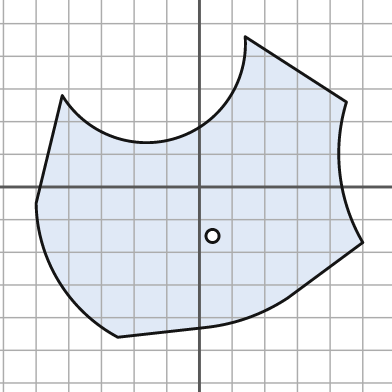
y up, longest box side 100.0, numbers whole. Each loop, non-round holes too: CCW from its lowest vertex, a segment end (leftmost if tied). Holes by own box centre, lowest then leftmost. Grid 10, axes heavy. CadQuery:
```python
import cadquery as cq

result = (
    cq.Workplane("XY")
    .moveTo(-25.0, -46.0)
    .lineTo(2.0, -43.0)
    .threePointArc((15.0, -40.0), (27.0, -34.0))
    .lineTo(50.0, -17.0)
    .threePointArc((43.0, 4.0), (45.0, 26.0))
    .lineTo(14.0, 46.0)
    .threePointArc((-7.0, 15.0), (-42.0, 28.0))
    .lineTo(-50.0, -5.0)
    .threePointArc((-43.0, -29.0), (-25.0, -46.0))
    .close()
    .moveTo(4.0, -15.0)
    .circle(2.0)
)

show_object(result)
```